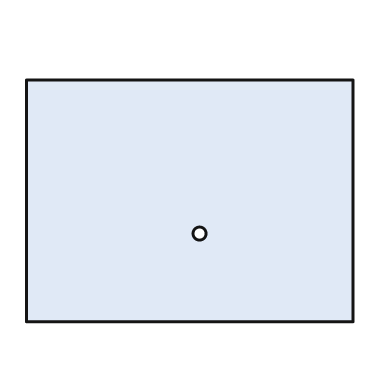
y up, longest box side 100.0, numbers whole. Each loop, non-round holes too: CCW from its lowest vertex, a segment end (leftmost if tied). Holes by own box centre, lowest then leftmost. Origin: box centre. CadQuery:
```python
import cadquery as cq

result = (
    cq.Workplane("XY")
    .moveTo(-50.0, -37.0)
    .lineTo(50.0, -37.0)
    .lineTo(50.0, 37.0)
    .lineTo(-50.0, 37.0)
    .close()
    .moveTo(3.0, -10.0)
    .circle(2.0)
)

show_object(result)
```